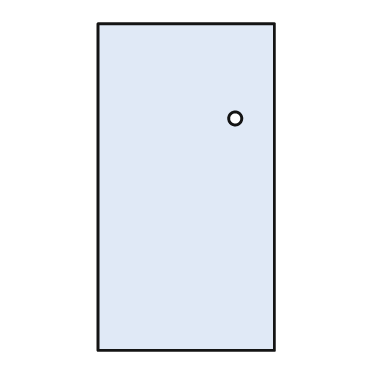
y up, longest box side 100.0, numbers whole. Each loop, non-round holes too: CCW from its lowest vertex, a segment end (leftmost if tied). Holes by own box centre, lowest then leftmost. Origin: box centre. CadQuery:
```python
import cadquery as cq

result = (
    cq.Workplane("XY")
    .moveTo(-27.0, -50.0)
    .lineTo(27.0, -50.0)
    .lineTo(27.0, 50.0)
    .lineTo(-27.0, 50.0)
    .close()
    .moveTo(15.0, 21.0)
    .circle(2.0)
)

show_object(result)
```